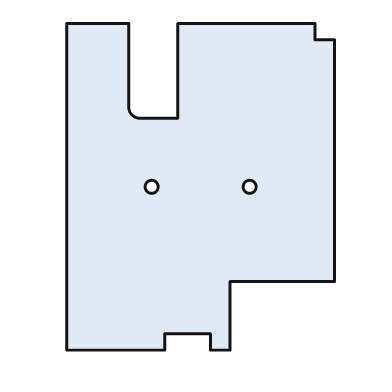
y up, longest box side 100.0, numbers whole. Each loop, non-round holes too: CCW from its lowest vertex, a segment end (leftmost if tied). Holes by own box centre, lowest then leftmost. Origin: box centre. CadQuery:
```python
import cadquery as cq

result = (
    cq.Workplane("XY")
    .moveTo(-41.0, -50.0)
    .lineTo(-11.0, -50.0)
    .lineTo(-11.0, -45.0)
    .lineTo(3.0, -45.0)
    .lineTo(3.0, -50.0)
    .lineTo(9.0, -50.0)
    .lineTo(9.0, -29.0)
    .lineTo(41.0, -29.0)
    .lineTo(41.0, 45.0)
    .lineTo(35.0, 45.0)
    .lineTo(35.0, 50.0)
    .lineTo(-7.0, 50.0)
    .lineTo(-7.0, 21.0)
    .lineTo(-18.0, 21.0)
    .threePointArc((-21.0, 22.0), (-22.0, 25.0))
    .lineTo(-22.0, 50.0)
    .lineTo(-41.0, 50.0)
    .close()
    .moveTo(-15.0, 0.0)
    .circle(2.0)
    .moveTo(15.0, 0.0)
    .circle(2.0)
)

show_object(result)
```